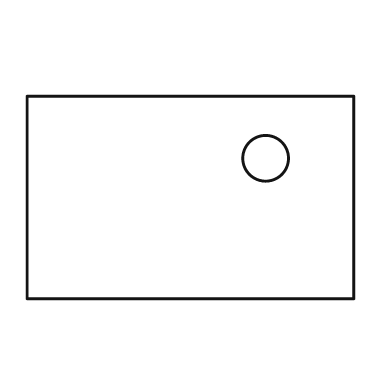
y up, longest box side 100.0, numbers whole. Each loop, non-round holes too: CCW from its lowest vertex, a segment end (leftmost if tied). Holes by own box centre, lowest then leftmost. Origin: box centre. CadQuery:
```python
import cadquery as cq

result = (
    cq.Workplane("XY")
    .moveTo(-50.0, -31.0)
    .lineTo(50.0, -31.0)
    .lineTo(50.0, 31.0)
    .lineTo(-50.0, 31.0)
    .close()
    .moveTo(23.0, 12.0)
    .circle(7.0)
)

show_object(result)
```